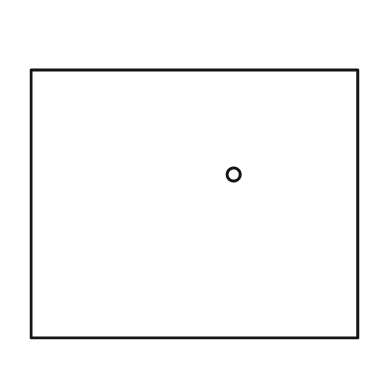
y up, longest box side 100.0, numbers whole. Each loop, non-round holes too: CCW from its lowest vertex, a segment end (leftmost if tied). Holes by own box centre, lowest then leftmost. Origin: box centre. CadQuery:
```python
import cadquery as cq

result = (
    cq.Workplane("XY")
    .moveTo(-50.0, -41.0)
    .lineTo(50.0, -41.0)
    .lineTo(50.0, 41.0)
    .lineTo(-50.0, 41.0)
    .close()
    .moveTo(12.0, 9.0)
    .circle(2.0)
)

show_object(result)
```